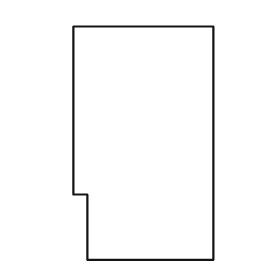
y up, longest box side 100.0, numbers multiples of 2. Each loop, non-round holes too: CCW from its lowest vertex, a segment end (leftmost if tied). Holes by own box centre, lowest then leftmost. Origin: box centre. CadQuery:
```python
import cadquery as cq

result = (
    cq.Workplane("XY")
    .moveTo(-24.0, -50.0)
    .lineTo(30.0, -50.0)
    .lineTo(30.0, 50.0)
    .lineTo(-30.0, 50.0)
    .lineTo(-30.0, -22.0)
    .lineTo(-24.0, -22.0)
    .close()
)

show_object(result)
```